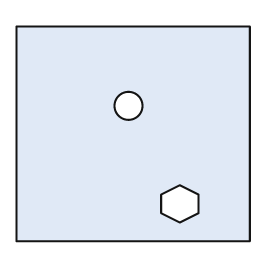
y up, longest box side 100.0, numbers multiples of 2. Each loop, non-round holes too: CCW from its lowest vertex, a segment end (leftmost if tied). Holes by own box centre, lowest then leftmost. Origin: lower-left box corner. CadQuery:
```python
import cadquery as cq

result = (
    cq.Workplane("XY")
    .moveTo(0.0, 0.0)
    .lineTo(100.0, 0.0)
    .lineTo(100.0, 92.0)
    .lineTo(0.0, 92.0)
    .close()
    .moveTo(70.0, 8.0)
    .lineTo(78.0, 12.0)
    .lineTo(78.0, 20.0)
    .lineTo(70.0, 24.0)
    .lineTo(62.0, 20.0)
    .lineTo(62.0, 12.0)
    .close()
    .moveTo(48.0, 58.0)
    .circle(6.0)
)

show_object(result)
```